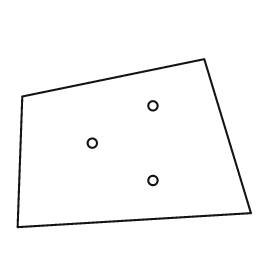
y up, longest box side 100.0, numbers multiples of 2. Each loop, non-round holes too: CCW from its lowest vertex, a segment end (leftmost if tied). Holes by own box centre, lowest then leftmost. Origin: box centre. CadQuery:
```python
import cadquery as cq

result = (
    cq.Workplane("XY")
    .moveTo(-50.0, -36.0)
    .lineTo(50.0, -30.0)
    .lineTo(30.0, 36.0)
    .lineTo(-48.0, 20.0)
    .close()
    .moveTo(8.0, -16.0)
    .circle(2.0)
    .moveTo(-18.0, 0.0)
    .circle(2.0)
    .moveTo(8.0, 16.0)
    .circle(2.0)
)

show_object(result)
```